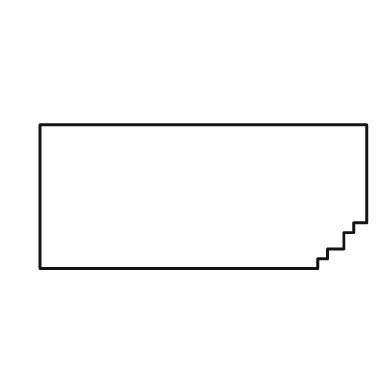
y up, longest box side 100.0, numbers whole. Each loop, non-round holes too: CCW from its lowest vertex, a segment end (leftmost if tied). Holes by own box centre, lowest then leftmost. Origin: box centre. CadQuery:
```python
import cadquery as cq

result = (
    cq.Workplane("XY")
    .moveTo(-50.0, -22.0)
    .lineTo(35.0, -22.0)
    .lineTo(35.0, -19.0)
    .lineTo(38.0, -19.0)
    .lineTo(38.0, -16.0)
    .lineTo(43.0, -16.0)
    .lineTo(43.0, -11.0)
    .lineTo(46.0, -11.0)
    .lineTo(46.0, -8.0)
    .lineTo(50.0, -8.0)
    .lineTo(50.0, 22.0)
    .lineTo(-50.0, 22.0)
    .close()
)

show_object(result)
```